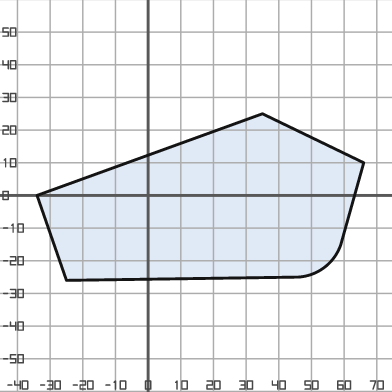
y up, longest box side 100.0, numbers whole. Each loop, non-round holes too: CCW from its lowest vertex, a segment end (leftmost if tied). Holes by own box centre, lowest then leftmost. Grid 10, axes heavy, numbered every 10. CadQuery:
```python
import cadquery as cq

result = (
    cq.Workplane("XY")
    .moveTo(-25.0, -26.0)
    .lineTo(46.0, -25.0)
    .threePointArc((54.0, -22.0), (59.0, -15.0))
    .lineTo(66.0, 10.0)
    .lineTo(35.0, 25.0)
    .lineTo(-34.0, 0.0)
    .close()
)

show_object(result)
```